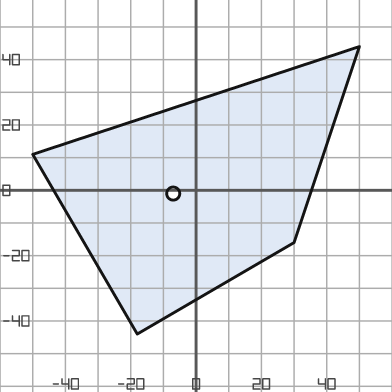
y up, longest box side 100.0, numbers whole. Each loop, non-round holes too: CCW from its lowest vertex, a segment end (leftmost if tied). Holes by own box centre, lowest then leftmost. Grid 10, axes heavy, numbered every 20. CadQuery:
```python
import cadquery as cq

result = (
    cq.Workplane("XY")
    .moveTo(-18.0, -44.0)
    .lineTo(30.0, -16.0)
    .lineTo(50.0, 44.0)
    .lineTo(-50.0, 11.0)
    .close()
    .moveTo(-7.0, -1.0)
    .circle(2.0)
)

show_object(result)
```